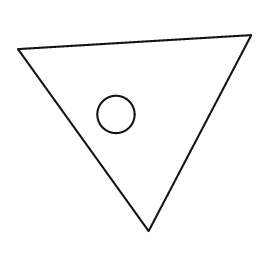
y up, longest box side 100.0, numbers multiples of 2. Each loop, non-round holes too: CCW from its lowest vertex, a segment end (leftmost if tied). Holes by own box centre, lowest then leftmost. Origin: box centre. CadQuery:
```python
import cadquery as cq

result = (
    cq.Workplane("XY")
    .moveTo(6.0, -42.0)
    .lineTo(50.0, 42.0)
    .lineTo(-50.0, 36.0)
    .close()
    .moveTo(-8.0, 8.0)
    .circle(8.0)
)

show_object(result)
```